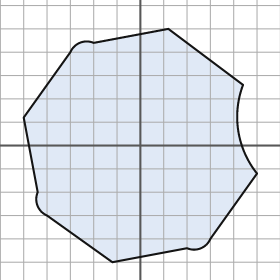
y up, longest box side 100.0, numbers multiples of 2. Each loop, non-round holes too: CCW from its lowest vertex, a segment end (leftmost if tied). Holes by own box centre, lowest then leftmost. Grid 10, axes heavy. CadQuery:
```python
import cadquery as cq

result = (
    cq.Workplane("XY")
    .moveTo(-12.0, -50.0)
    .lineTo(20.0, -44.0)
    .threePointArc((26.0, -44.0), (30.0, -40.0))
    .lineTo(50.0, -12.0)
    .threePointArc((42.0, 6.0), (44.0, 26.0))
    .lineTo(12.0, 50.0)
    .lineTo(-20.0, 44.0)
    .threePointArc((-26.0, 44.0), (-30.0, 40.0))
    .lineTo(-50.0, 12.0)
    .lineTo(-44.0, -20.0)
    .threePointArc((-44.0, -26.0), (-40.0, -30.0))
    .close()
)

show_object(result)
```